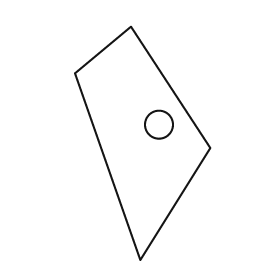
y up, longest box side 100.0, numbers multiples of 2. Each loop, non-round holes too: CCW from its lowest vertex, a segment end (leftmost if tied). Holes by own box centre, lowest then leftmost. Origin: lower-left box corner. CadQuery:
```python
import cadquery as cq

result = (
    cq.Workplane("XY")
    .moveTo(28.0, 0.0)
    .lineTo(58.0, 48.0)
    .lineTo(24.0, 100.0)
    .lineTo(0.0, 80.0)
    .close()
    .moveTo(36.0, 58.0)
    .circle(6.0)
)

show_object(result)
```